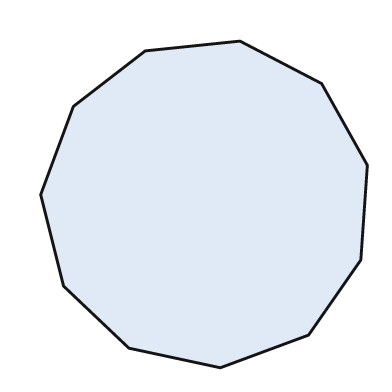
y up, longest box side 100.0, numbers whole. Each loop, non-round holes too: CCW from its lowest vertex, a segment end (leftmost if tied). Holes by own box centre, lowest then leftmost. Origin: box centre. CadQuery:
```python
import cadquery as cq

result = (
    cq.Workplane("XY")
    .moveTo(5.0, -50.0)
    .lineTo(32.0, -40.0)
    .lineTo(48.0, -17.0)
    .lineTo(50.0, 12.0)
    .lineTo(36.0, 37.0)
    .lineTo(11.0, 50.0)
    .lineTo(-18.0, 47.0)
    .lineTo(-40.0, 30.0)
    .lineTo(-50.0, 3.0)
    .lineTo(-43.0, -25.0)
    .lineTo(-23.0, -44.0)
    .close()
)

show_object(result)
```